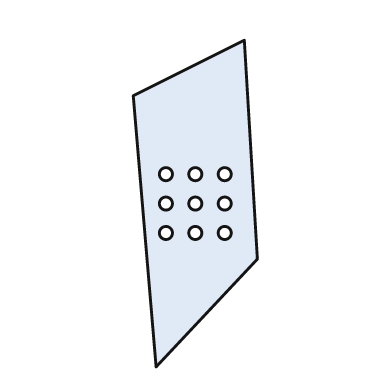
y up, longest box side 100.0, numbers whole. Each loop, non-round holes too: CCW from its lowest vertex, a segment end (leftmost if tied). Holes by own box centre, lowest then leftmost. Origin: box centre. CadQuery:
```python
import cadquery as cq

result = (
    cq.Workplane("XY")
    .moveTo(-12.0, -50.0)
    .lineTo(19.0, -17.0)
    .lineTo(15.0, 50.0)
    .lineTo(-19.0, 33.0)
    .close()
    .moveTo(-9.0, -9.0)
    .circle(2.0)
    .moveTo(0.0, -9.0)
    .circle(2.0)
    .moveTo(9.0, -9.0)
    .circle(2.0)
    .moveTo(-9.0, 0.0)
    .circle(2.0)
    .moveTo(0.0, 0.0)
    .circle(2.0)
    .moveTo(9.0, 0.0)
    .circle(2.0)
    .moveTo(-9.0, 9.0)
    .circle(2.0)
    .moveTo(0.0, 9.0)
    .circle(2.0)
    .moveTo(9.0, 9.0)
    .circle(2.0)
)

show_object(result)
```